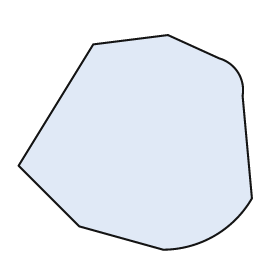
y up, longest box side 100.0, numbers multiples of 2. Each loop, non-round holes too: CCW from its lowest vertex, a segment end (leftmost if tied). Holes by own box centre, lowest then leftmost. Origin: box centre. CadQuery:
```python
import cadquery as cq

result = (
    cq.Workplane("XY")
    .moveTo(12.0, -46.0)
    .threePointArc((34.0, -40.0), (50.0, -24.0))
    .lineTo(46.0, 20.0)
    .threePointArc((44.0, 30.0), (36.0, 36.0))
    .lineTo(14.0, 46.0)
    .lineTo(-18.0, 42.0)
    .lineTo(-50.0, -10.0)
    .lineTo(-24.0, -36.0)
    .close()
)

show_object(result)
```